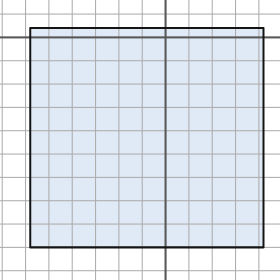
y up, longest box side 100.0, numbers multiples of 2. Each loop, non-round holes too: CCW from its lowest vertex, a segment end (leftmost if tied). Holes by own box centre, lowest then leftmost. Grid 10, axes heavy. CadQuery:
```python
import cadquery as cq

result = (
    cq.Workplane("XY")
    .moveTo(-58.0, -90.0)
    .lineTo(42.0, -90.0)
    .lineTo(42.0, 4.0)
    .lineTo(-58.0, 4.0)
    .close()
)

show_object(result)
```